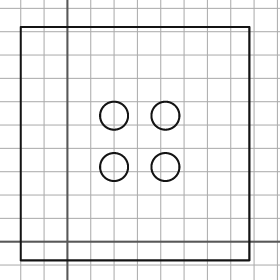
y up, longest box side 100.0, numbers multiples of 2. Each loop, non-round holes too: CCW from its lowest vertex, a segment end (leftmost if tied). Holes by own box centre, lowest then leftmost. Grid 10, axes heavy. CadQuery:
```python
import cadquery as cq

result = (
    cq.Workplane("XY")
    .moveTo(-20.0, -8.0)
    .lineTo(78.0, -8.0)
    .lineTo(78.0, 92.0)
    .lineTo(-20.0, 92.0)
    .close()
    .moveTo(20.0, 32.0)
    .circle(6.0)
    .moveTo(42.0, 32.0)
    .circle(6.0)
    .moveTo(20.0, 54.0)
    .circle(6.0)
    .moveTo(42.0, 54.0)
    .circle(6.0)
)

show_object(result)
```